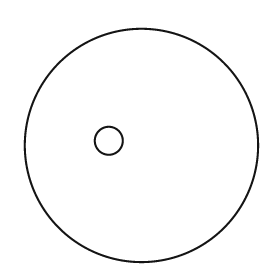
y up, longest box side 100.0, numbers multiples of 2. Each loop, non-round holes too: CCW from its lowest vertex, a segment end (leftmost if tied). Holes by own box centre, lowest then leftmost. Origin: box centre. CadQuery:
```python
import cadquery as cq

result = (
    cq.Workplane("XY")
    .moveTo(0.0, 0.0)
    .circle(50.0)
    .moveTo(-14.0, 2.0)
    .circle(6.0)
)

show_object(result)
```